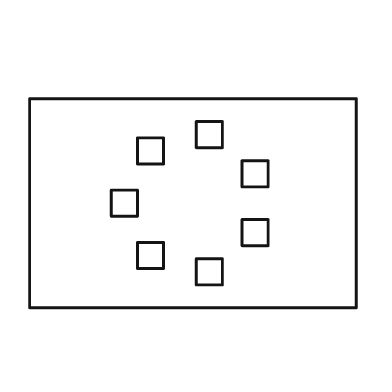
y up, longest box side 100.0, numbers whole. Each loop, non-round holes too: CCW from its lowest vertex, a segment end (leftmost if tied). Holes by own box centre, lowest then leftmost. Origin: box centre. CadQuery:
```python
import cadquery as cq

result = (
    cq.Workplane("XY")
    .moveTo(-50.0, -32.0)
    .lineTo(50.0, -32.0)
    .lineTo(50.0, 32.0)
    .lineTo(-50.0, 32.0)
    .close()
    .moveTo(1.0, -25.0)
    .lineTo(9.0, -25.0)
    .lineTo(9.0, -17.0)
    .lineTo(1.0, -17.0)
    .close()
    .moveTo(-17.0, -20.0)
    .lineTo(-9.0, -20.0)
    .lineTo(-9.0, -12.0)
    .lineTo(-17.0, -12.0)
    .close()
    .moveTo(15.0, -13.0)
    .lineTo(23.0, -13.0)
    .lineTo(23.0, -5.0)
    .lineTo(15.0, -5.0)
    .close()
    .moveTo(-25.0, -4.0)
    .lineTo(-17.0, -4.0)
    .lineTo(-17.0, 4.0)
    .lineTo(-25.0, 4.0)
    .close()
    .moveTo(15.0, 5.0)
    .lineTo(23.0, 5.0)
    .lineTo(23.0, 13.0)
    .lineTo(15.0, 13.0)
    .close()
    .moveTo(-17.0, 12.0)
    .lineTo(-9.0, 12.0)
    .lineTo(-9.0, 20.0)
    .lineTo(-17.0, 20.0)
    .close()
    .moveTo(1.0, 17.0)
    .lineTo(9.0, 17.0)
    .lineTo(9.0, 25.0)
    .lineTo(1.0, 25.0)
    .close()
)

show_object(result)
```